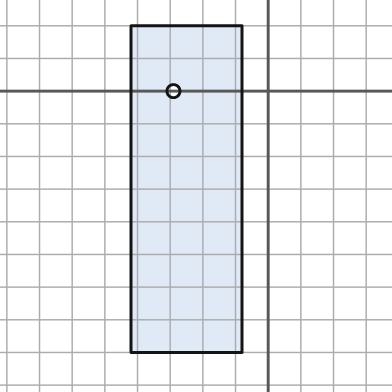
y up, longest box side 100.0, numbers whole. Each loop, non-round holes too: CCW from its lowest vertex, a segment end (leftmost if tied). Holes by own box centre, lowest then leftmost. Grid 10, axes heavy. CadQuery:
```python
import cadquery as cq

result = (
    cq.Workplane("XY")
    .moveTo(-42.0, -80.0)
    .lineTo(-8.0, -80.0)
    .lineTo(-8.0, 20.0)
    .lineTo(-42.0, 20.0)
    .close()
    .moveTo(-29.0, 0.0)
    .circle(2.0)
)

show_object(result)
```